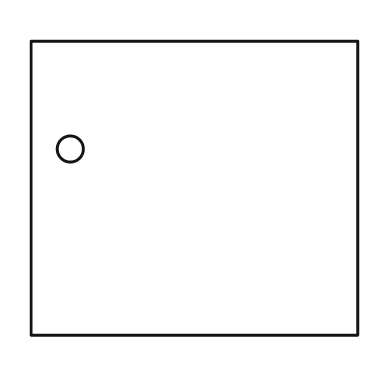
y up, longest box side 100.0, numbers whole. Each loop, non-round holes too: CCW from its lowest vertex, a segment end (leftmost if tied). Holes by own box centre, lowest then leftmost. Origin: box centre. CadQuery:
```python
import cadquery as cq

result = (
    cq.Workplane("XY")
    .moveTo(-50.0, -45.0)
    .lineTo(50.0, -45.0)
    .lineTo(50.0, 45.0)
    .lineTo(-50.0, 45.0)
    .close()
    .moveTo(-38.0, 12.0)
    .circle(4.0)
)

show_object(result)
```